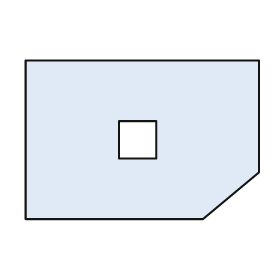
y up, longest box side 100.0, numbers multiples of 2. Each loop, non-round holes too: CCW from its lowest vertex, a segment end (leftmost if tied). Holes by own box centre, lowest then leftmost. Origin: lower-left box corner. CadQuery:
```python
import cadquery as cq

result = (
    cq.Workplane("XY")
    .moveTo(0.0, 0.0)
    .lineTo(76.0, 0.0)
    .lineTo(100.0, 20.0)
    .lineTo(100.0, 68.0)
    .lineTo(0.0, 68.0)
    .close()
    .moveTo(40.0, 26.0)
    .lineTo(56.0, 26.0)
    .lineTo(56.0, 42.0)
    .lineTo(40.0, 42.0)
    .close()
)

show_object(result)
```